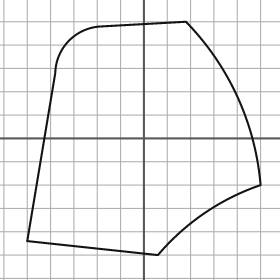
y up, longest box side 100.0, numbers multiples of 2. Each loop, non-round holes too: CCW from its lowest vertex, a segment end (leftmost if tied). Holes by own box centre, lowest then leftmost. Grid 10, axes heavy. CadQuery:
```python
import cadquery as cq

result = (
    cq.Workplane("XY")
    .moveTo(6.0, -50.0)
    .threePointArc((26.0, -32.0), (50.0, -20.0))
    .threePointArc((40.0, 18.0), (18.0, 50.0))
    .lineTo(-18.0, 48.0)
    .threePointArc((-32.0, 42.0), (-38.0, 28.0))
    .lineTo(-50.0, -44.0)
    .close()
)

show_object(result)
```